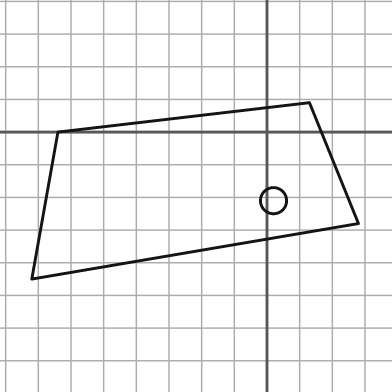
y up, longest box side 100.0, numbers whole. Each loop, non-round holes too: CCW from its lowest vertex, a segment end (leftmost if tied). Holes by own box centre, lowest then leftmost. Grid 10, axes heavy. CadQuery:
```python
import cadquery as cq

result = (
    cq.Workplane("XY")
    .moveTo(-72.0, -45.0)
    .lineTo(28.0, -28.0)
    .lineTo(13.0, 9.0)
    .lineTo(-64.0, 0.0)
    .close()
    .moveTo(2.0, -21.0)
    .circle(4.0)
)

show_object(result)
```